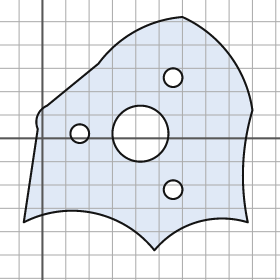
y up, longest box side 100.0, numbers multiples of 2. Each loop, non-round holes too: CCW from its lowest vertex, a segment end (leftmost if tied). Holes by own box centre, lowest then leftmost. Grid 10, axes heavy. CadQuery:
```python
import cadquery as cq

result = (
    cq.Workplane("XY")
    .moveTo(48.0, -48.0)
    .threePointArc((66.0, -36.0), (88.0, -36.0))
    .threePointArc((86.0, -12.0), (90.0, 12.0))
    .threePointArc((80.0, 36.0), (60.0, 52.0))
    .threePointArc((40.0, 46.0), (24.0, 32.0))
    .lineTo(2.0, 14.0)
    .threePointArc((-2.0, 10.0), (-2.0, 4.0))
    .lineTo(-8.0, -36.0)
    .threePointArc((22.0, -32.0), (48.0, -48.0))
    .close()
    .moveTo(56.0, -22.0)
    .circle(4.0)
    .moveTo(16.0, 2.0)
    .circle(4.0)
    .moveTo(42.0, 2.0)
    .circle(12.0)
    .moveTo(56.0, 26.0)
    .circle(4.0)
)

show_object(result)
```